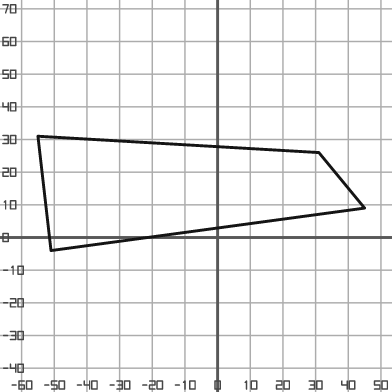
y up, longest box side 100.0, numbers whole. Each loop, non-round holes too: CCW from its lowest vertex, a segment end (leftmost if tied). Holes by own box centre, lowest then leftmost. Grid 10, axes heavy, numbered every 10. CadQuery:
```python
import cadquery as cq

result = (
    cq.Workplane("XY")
    .moveTo(-51.0, -4.0)
    .lineTo(45.0, 9.0)
    .lineTo(31.0, 26.0)
    .lineTo(-55.0, 31.0)
    .close()
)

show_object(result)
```